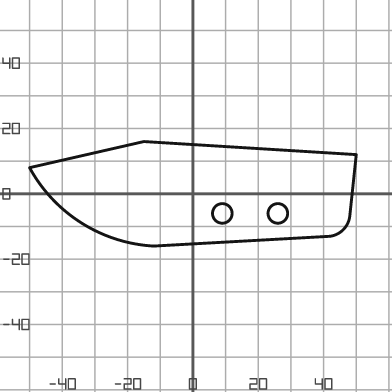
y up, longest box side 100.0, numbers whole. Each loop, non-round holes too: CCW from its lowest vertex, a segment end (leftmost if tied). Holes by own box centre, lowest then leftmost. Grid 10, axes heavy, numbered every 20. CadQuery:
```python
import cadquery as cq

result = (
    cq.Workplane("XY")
    .moveTo(-12.0, -16.0)
    .lineTo(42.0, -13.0)
    .threePointArc((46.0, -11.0), (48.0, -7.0))
    .lineTo(50.0, 12.0)
    .lineTo(-15.0, 16.0)
    .lineTo(-50.0, 8.0)
    .threePointArc((-34.0, -9.0), (-12.0, -16.0))
    .close()
    .moveTo(9.0, -6.0)
    .circle(3.0)
    .moveTo(26.0, -6.0)
    .circle(3.0)
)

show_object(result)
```